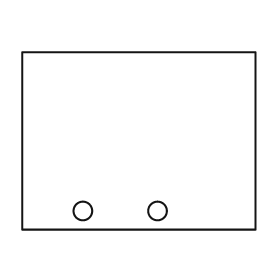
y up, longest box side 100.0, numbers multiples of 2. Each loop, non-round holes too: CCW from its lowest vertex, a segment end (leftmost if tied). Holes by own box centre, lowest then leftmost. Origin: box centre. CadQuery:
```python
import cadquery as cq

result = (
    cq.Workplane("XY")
    .moveTo(-50.0, -38.0)
    .lineTo(50.0, -38.0)
    .lineTo(50.0, 38.0)
    .lineTo(-50.0, 38.0)
    .close()
    .moveTo(-24.0, -30.0)
    .circle(4.0)
    .moveTo(8.0, -30.0)
    .circle(4.0)
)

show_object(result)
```